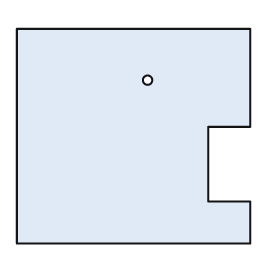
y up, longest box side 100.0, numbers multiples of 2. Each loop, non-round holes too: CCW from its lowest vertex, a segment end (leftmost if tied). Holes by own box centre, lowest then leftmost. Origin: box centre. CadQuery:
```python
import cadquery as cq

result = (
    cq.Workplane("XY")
    .moveTo(-50.0, -46.0)
    .lineTo(50.0, -46.0)
    .lineTo(50.0, -28.0)
    .lineTo(32.0, -28.0)
    .lineTo(32.0, 4.0)
    .lineTo(50.0, 4.0)
    .lineTo(50.0, 46.0)
    .lineTo(-50.0, 46.0)
    .close()
    .moveTo(6.0, 24.0)
    .circle(2.0)
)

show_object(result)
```